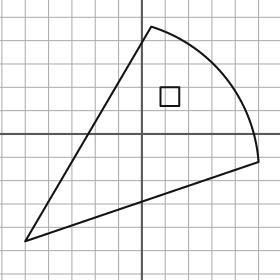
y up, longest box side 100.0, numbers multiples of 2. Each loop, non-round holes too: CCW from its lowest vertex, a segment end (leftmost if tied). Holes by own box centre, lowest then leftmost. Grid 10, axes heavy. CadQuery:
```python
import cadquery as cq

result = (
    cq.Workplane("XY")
    .moveTo(-50.0, -46.0)
    .lineTo(50.0, -12.0)
    .threePointArc((36.0, 24.0), (4.0, 46.0))
    .close()
    .moveTo(8.0, 12.0)
    .lineTo(16.0, 12.0)
    .lineTo(16.0, 20.0)
    .lineTo(8.0, 20.0)
    .close()
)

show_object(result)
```